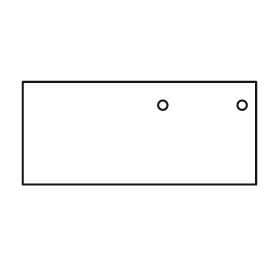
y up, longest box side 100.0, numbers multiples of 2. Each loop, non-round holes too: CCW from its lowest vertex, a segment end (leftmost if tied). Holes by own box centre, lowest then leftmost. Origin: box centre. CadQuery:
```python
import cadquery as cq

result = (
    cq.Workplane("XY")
    .moveTo(-50.0, -22.0)
    .lineTo(50.0, -22.0)
    .lineTo(50.0, 22.0)
    .lineTo(-50.0, 22.0)
    .close()
    .moveTo(10.0, 12.0)
    .circle(2.0)
    .moveTo(44.0, 12.0)
    .circle(2.0)
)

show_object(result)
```